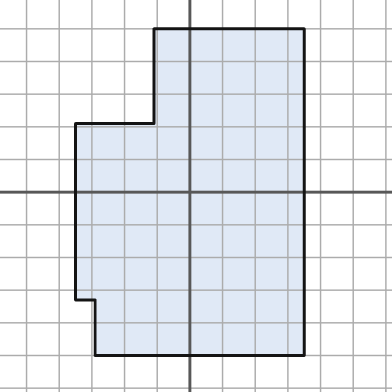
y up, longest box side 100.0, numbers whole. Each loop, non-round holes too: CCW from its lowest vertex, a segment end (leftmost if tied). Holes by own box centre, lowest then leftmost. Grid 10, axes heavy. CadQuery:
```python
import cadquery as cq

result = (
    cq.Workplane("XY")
    .moveTo(-29.0, -50.0)
    .lineTo(35.0, -50.0)
    .lineTo(35.0, 50.0)
    .lineTo(-11.0, 50.0)
    .lineTo(-11.0, 21.0)
    .lineTo(-35.0, 21.0)
    .lineTo(-35.0, -33.0)
    .lineTo(-29.0, -33.0)
    .close()
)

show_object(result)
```